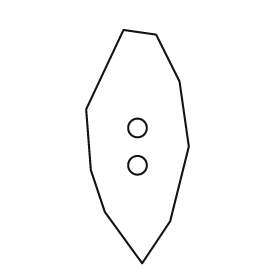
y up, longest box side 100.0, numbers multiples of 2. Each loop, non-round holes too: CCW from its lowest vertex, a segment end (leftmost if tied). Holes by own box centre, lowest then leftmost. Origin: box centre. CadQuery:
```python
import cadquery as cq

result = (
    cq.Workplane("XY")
    .moveTo(2.0, -50.0)
    .lineTo(14.0, -32.0)
    .lineTo(22.0, 0.0)
    .lineTo(18.0, 28.0)
    .lineTo(8.0, 48.0)
    .lineTo(-6.0, 50.0)
    .lineTo(-22.0, 16.0)
    .lineTo(-20.0, -10.0)
    .lineTo(-14.0, -28.0)
    .close()
    .moveTo(0.0, -8.0)
    .circle(4.0)
    .moveTo(0.0, 8.0)
    .circle(4.0)
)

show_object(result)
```